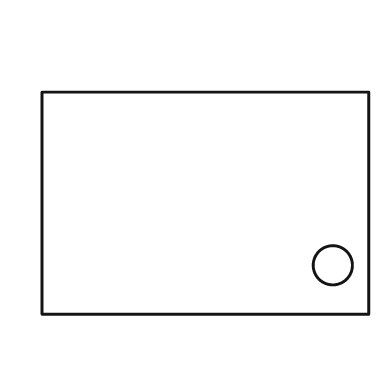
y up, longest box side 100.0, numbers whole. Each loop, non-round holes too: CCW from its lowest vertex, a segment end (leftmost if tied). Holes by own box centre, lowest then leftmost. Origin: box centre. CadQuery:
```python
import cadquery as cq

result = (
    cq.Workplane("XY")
    .moveTo(-50.0, -34.0)
    .lineTo(50.0, -34.0)
    .lineTo(50.0, 34.0)
    .lineTo(-50.0, 34.0)
    .close()
    .moveTo(39.0, -19.0)
    .circle(6.0)
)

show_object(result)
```